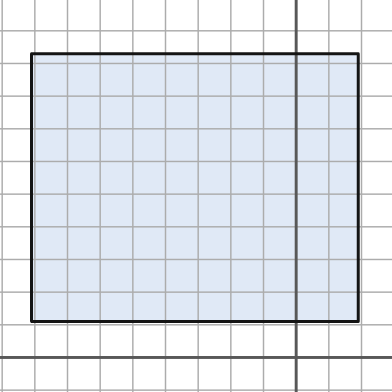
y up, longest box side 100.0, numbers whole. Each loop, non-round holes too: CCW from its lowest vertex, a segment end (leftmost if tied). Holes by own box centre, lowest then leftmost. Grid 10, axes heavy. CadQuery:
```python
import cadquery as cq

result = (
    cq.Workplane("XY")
    .moveTo(-81.0, 11.0)
    .lineTo(19.0, 11.0)
    .lineTo(19.0, 93.0)
    .lineTo(-81.0, 93.0)
    .close()
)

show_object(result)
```